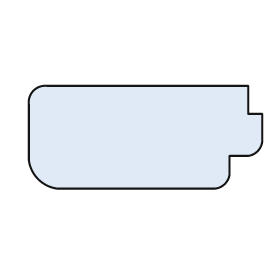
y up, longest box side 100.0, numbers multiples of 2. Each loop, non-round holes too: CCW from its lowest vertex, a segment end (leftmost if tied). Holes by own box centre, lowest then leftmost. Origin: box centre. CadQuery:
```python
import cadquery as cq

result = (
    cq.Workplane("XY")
    .moveTo(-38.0, -22.0)
    .lineTo(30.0, -22.0)
    .threePointArc((34.0, -20.0), (36.0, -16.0))
    .lineTo(36.0, -8.0)
    .lineTo(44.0, -8.0)
    .threePointArc((48.0, -6.0), (50.0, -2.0))
    .lineTo(50.0, 10.0)
    .lineTo(44.0, 10.0)
    .lineTo(44.0, 22.0)
    .lineTo(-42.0, 22.0)
    .threePointArc((-48.0, 20.0), (-50.0, 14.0))
    .lineTo(-50.0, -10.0)
    .threePointArc((-46.0, -18.0), (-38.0, -22.0))
    .close()
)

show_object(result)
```